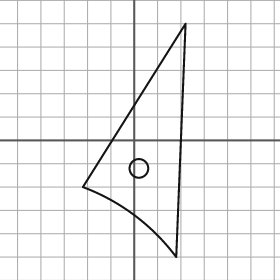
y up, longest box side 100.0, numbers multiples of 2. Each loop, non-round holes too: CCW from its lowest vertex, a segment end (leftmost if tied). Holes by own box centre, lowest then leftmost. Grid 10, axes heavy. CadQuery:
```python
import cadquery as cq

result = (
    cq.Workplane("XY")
    .moveTo(18.0, -50.0)
    .lineTo(22.0, 50.0)
    .lineTo(-22.0, -20.0)
    .threePointArc((0.0, -32.0), (18.0, -50.0))
    .close()
    .moveTo(2.0, -12.0)
    .circle(4.0)
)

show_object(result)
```